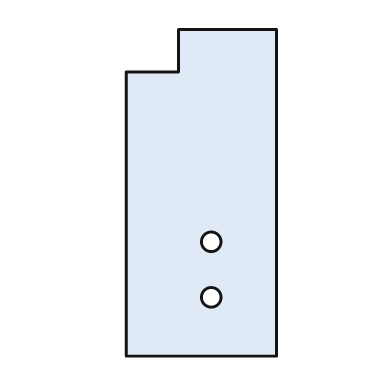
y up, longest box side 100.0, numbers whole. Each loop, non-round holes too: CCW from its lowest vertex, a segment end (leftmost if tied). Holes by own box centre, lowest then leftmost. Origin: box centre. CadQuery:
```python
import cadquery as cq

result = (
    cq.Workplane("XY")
    .moveTo(-23.0, -50.0)
    .lineTo(23.0, -50.0)
    .lineTo(23.0, 50.0)
    .lineTo(-7.0, 50.0)
    .lineTo(-7.0, 37.0)
    .lineTo(-23.0, 37.0)
    .close()
    .moveTo(3.0, -32.0)
    .circle(3.0)
    .moveTo(3.0, -15.0)
    .circle(3.0)
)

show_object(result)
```